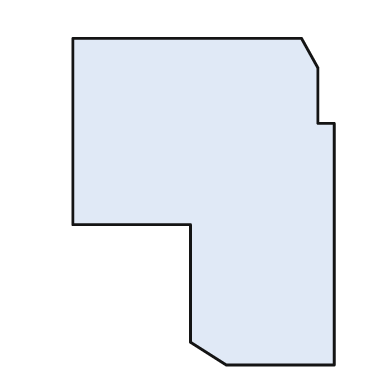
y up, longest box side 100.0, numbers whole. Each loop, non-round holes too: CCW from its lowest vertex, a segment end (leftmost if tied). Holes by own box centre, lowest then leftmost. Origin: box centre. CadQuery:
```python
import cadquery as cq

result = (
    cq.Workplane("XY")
    .moveTo(7.0, -50.0)
    .lineTo(40.0, -50.0)
    .lineTo(40.0, 24.0)
    .lineTo(35.0, 24.0)
    .lineTo(35.0, 41.0)
    .lineTo(30.0, 50.0)
    .lineTo(-40.0, 50.0)
    .lineTo(-40.0, -7.0)
    .lineTo(-4.0, -7.0)
    .lineTo(-4.0, -43.0)
    .close()
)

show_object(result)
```